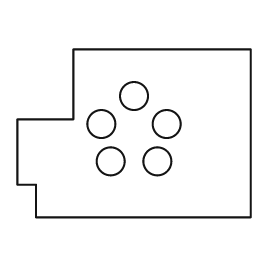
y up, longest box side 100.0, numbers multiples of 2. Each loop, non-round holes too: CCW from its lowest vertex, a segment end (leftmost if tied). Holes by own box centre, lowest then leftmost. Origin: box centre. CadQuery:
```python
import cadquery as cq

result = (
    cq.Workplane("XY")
    .moveTo(-42.0, -36.0)
    .lineTo(50.0, -36.0)
    .lineTo(50.0, 36.0)
    .lineTo(-26.0, 36.0)
    .lineTo(-26.0, 6.0)
    .lineTo(-50.0, 6.0)
    .lineTo(-50.0, -22.0)
    .lineTo(-42.0, -22.0)
    .close()
    .moveTo(-10.0, -12.0)
    .circle(6.0)
    .moveTo(10.0, -12.0)
    .circle(6.0)
    .moveTo(-14.0, 4.0)
    .circle(6.0)
    .moveTo(14.0, 4.0)
    .circle(6.0)
    .moveTo(0.0, 16.0)
    .circle(6.0)
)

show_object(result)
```